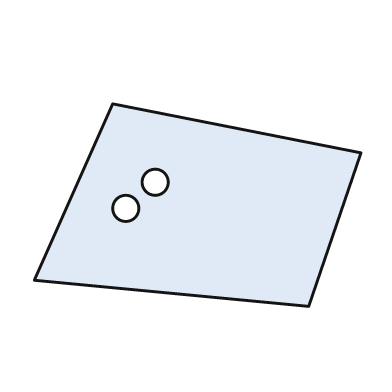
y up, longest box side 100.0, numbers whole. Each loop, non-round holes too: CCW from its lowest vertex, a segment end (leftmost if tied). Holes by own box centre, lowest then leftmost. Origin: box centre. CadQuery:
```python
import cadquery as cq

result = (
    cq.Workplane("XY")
    .moveTo(34.0, -31.0)
    .lineTo(50.0, 16.0)
    .lineTo(-26.0, 31.0)
    .lineTo(-50.0, -23.0)
    .close()
    .moveTo(-22.0, -1.0)
    .circle(4.0)
    .moveTo(-13.0, 7.0)
    .circle(4.0)
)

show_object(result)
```